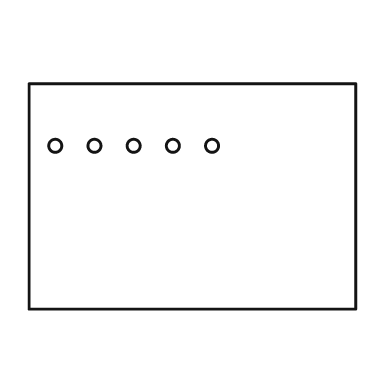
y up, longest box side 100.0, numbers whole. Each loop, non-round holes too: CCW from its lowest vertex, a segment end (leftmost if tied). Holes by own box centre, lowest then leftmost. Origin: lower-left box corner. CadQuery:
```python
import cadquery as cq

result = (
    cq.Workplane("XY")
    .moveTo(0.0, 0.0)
    .lineTo(100.0, 0.0)
    .lineTo(100.0, 69.0)
    .lineTo(0.0, 69.0)
    .close()
    .moveTo(8.0, 50.0)
    .circle(2.0)
    .moveTo(20.0, 50.0)
    .circle(2.0)
    .moveTo(32.0, 50.0)
    .circle(2.0)
    .moveTo(44.0, 50.0)
    .circle(2.0)
    .moveTo(56.0, 50.0)
    .circle(2.0)
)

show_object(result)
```